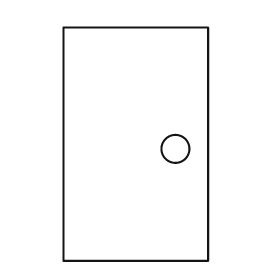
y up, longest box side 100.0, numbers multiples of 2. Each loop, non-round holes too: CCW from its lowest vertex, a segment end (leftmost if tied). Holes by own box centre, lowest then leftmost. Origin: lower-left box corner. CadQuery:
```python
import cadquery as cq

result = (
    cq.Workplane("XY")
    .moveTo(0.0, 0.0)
    .lineTo(62.0, 0.0)
    .lineTo(62.0, 100.0)
    .lineTo(0.0, 100.0)
    .close()
    .moveTo(48.0, 48.0)
    .circle(6.0)
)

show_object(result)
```